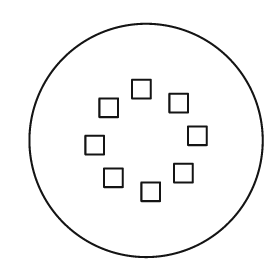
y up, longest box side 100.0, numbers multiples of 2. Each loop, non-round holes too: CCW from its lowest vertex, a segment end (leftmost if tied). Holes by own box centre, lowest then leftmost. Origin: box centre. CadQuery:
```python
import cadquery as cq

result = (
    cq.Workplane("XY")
    .moveTo(0.0, 0.0)
    .circle(50.0)
    .moveTo(-2.0, -26.0)
    .lineTo(6.0, -26.0)
    .lineTo(6.0, -18.0)
    .lineTo(-2.0, -18.0)
    .close()
    .moveTo(-18.0, -20.0)
    .lineTo(-10.0, -20.0)
    .lineTo(-10.0, -12.0)
    .lineTo(-18.0, -12.0)
    .close()
    .moveTo(12.0, -18.0)
    .lineTo(20.0, -18.0)
    .lineTo(20.0, -10.0)
    .lineTo(12.0, -10.0)
    .close()
    .moveTo(-26.0, -6.0)
    .lineTo(-18.0, -6.0)
    .lineTo(-18.0, 2.0)
    .lineTo(-26.0, 2.0)
    .close()
    .moveTo(18.0, -2.0)
    .lineTo(26.0, -2.0)
    .lineTo(26.0, 6.0)
    .lineTo(18.0, 6.0)
    .close()
    .moveTo(-20.0, 10.0)
    .lineTo(-12.0, 10.0)
    .lineTo(-12.0, 18.0)
    .lineTo(-20.0, 18.0)
    .close()
    .moveTo(10.0, 12.0)
    .lineTo(18.0, 12.0)
    .lineTo(18.0, 20.0)
    .lineTo(10.0, 20.0)
    .close()
    .moveTo(-6.0, 18.0)
    .lineTo(2.0, 18.0)
    .lineTo(2.0, 26.0)
    .lineTo(-6.0, 26.0)
    .close()
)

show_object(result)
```